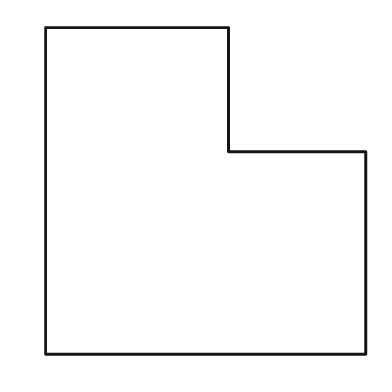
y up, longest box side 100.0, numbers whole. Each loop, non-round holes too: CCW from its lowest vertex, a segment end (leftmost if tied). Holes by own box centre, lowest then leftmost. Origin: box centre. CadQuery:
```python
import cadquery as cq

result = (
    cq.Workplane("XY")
    .moveTo(-49.0, -50.0)
    .lineTo(49.0, -50.0)
    .lineTo(49.0, 12.0)
    .lineTo(7.0, 12.0)
    .lineTo(7.0, 50.0)
    .lineTo(-49.0, 50.0)
    .close()
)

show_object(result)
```